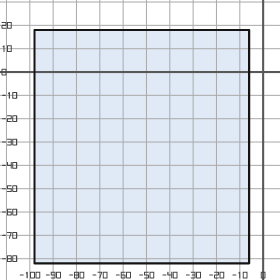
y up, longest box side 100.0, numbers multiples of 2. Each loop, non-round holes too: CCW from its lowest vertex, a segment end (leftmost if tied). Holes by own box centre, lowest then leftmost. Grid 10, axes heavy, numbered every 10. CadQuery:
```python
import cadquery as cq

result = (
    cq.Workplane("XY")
    .moveTo(-98.0, -82.0)
    .lineTo(-6.0, -82.0)
    .lineTo(-6.0, 18.0)
    .lineTo(-98.0, 18.0)
    .close()
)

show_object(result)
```